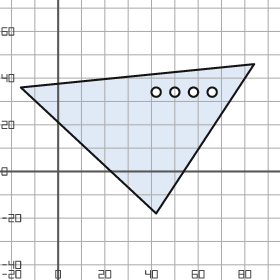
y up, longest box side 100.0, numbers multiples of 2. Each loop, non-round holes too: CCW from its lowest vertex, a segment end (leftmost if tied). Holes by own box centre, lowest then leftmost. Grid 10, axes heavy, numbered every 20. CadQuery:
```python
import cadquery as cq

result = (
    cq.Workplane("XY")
    .moveTo(42.0, -18.0)
    .lineTo(84.0, 46.0)
    .lineTo(-16.0, 36.0)
    .close()
    .moveTo(42.0, 34.0)
    .circle(2.0)
    .moveTo(50.0, 34.0)
    .circle(2.0)
    .moveTo(58.0, 34.0)
    .circle(2.0)
    .moveTo(66.0, 34.0)
    .circle(2.0)
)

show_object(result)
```